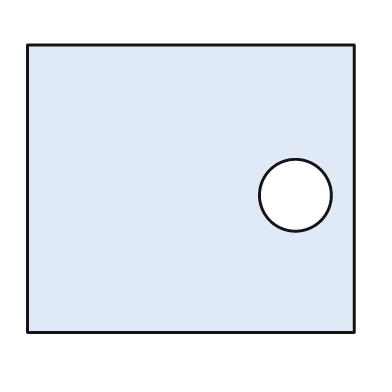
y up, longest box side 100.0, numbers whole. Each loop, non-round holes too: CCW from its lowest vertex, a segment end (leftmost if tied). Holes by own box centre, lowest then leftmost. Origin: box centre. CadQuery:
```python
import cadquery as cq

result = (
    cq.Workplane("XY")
    .moveTo(-50.0, -44.0)
    .lineTo(50.0, -44.0)
    .lineTo(50.0, 44.0)
    .lineTo(-50.0, 44.0)
    .close()
    .moveTo(32.0, -2.0)
    .circle(11.0)
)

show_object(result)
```